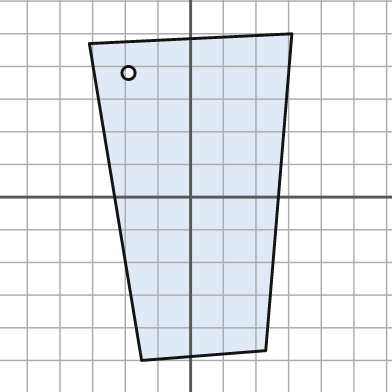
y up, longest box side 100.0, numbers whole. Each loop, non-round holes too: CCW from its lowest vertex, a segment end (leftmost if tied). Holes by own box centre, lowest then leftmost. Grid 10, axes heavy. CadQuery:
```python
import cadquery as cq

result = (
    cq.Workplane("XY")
    .moveTo(-15.0, -50.0)
    .lineTo(23.0, -47.0)
    .lineTo(31.0, 50.0)
    .lineTo(-31.0, 47.0)
    .close()
    .moveTo(-19.0, 38.0)
    .circle(2.0)
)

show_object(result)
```